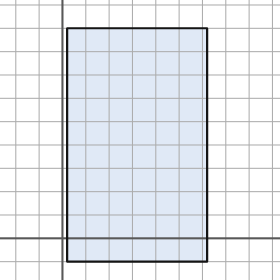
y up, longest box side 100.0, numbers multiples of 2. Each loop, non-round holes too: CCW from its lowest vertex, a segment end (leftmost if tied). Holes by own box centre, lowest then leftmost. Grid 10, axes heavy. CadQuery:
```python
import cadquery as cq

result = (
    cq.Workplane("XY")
    .moveTo(2.0, -10.0)
    .lineTo(62.0, -10.0)
    .lineTo(62.0, 90.0)
    .lineTo(2.0, 90.0)
    .close()
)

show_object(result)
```